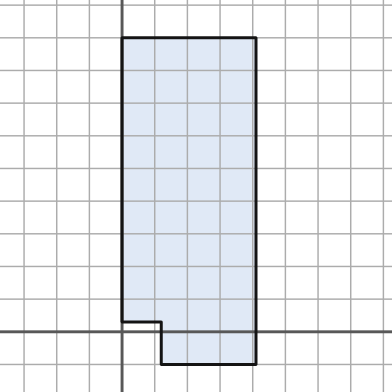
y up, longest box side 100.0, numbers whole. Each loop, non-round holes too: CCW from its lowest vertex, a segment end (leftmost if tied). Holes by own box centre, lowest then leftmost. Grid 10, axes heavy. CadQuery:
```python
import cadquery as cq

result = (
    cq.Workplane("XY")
    .moveTo(12.0, -10.0)
    .lineTo(41.0, -10.0)
    .lineTo(41.0, 90.0)
    .lineTo(0.0, 90.0)
    .lineTo(0.0, 3.0)
    .lineTo(12.0, 3.0)
    .close()
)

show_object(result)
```